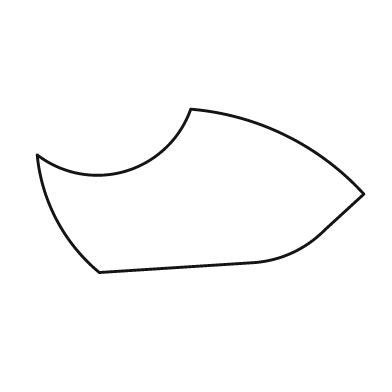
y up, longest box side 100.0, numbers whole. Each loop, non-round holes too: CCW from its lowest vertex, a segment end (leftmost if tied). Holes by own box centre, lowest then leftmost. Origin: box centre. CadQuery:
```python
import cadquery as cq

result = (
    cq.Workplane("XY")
    .moveTo(-31.0, -25.0)
    .lineTo(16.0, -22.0)
    .threePointArc((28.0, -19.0), (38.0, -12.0))
    .lineTo(50.0, -1.0)
    .threePointArc((26.0, 17.0), (-3.0, 25.0))
    .threePointArc((-23.0, 6.0), (-50.0, 11.0))
    .threePointArc((-44.0, -9.0), (-31.0, -25.0))
    .close()
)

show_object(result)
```